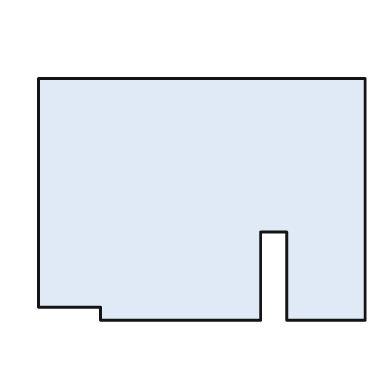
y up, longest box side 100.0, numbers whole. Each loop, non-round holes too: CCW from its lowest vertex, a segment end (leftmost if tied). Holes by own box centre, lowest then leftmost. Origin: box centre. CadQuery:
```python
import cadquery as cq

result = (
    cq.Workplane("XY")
    .moveTo(-31.0, -37.0)
    .lineTo(18.0, -37.0)
    .lineTo(18.0, -10.0)
    .lineTo(26.0, -10.0)
    .lineTo(26.0, -37.0)
    .lineTo(50.0, -37.0)
    .lineTo(50.0, 37.0)
    .lineTo(-50.0, 37.0)
    .lineTo(-50.0, -33.0)
    .lineTo(-31.0, -33.0)
    .close()
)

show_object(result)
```